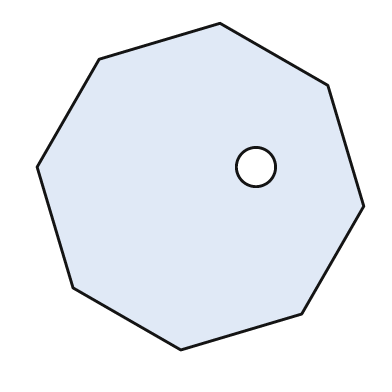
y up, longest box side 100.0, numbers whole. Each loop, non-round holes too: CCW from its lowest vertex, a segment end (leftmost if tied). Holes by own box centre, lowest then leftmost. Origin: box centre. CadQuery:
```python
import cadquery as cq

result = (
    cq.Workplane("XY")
    .moveTo(-6.0, -50.0)
    .lineTo(31.0, -39.0)
    .lineTo(50.0, -6.0)
    .lineTo(39.0, 31.0)
    .lineTo(6.0, 50.0)
    .lineTo(-31.0, 39.0)
    .lineTo(-50.0, 6.0)
    .lineTo(-39.0, -31.0)
    .close()
    .moveTo(17.0, 6.0)
    .circle(6.0)
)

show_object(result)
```